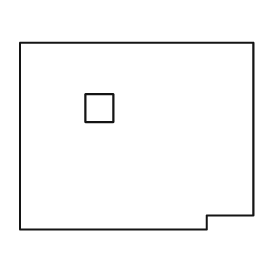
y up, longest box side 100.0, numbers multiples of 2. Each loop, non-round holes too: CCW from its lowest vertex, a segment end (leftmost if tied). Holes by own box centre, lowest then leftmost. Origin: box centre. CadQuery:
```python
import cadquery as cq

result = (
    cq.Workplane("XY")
    .moveTo(-50.0, -40.0)
    .lineTo(30.0, -40.0)
    .lineTo(30.0, -34.0)
    .lineTo(50.0, -34.0)
    .lineTo(50.0, 40.0)
    .lineTo(-50.0, 40.0)
    .close()
    .moveTo(-22.0, 6.0)
    .lineTo(-10.0, 6.0)
    .lineTo(-10.0, 18.0)
    .lineTo(-22.0, 18.0)
    .close()
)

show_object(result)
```